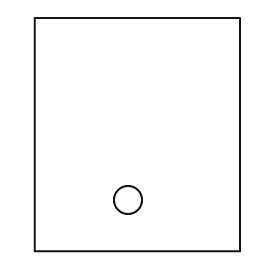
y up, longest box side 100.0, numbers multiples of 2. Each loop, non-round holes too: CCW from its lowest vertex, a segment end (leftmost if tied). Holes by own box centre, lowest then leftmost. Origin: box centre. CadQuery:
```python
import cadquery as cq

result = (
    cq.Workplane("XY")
    .moveTo(-44.0, -50.0)
    .lineTo(44.0, -50.0)
    .lineTo(44.0, 50.0)
    .lineTo(-44.0, 50.0)
    .close()
    .moveTo(-4.0, -28.0)
    .circle(6.0)
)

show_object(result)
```